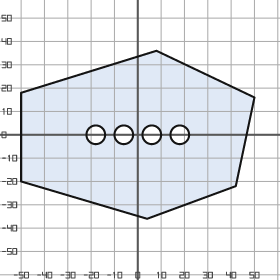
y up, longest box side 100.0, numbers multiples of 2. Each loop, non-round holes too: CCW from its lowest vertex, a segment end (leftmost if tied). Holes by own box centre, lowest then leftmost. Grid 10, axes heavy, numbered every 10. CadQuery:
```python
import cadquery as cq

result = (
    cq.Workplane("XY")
    .moveTo(4.0, -36.0)
    .lineTo(42.0, -22.0)
    .lineTo(50.0, 16.0)
    .lineTo(8.0, 36.0)
    .lineTo(-50.0, 18.0)
    .lineTo(-50.0, -20.0)
    .close()
    .moveTo(-18.0, 0.0)
    .circle(4.0)
    .moveTo(-6.0, 0.0)
    .circle(4.0)
    .moveTo(6.0, 0.0)
    .circle(4.0)
    .moveTo(18.0, 0.0)
    .circle(4.0)
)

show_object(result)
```